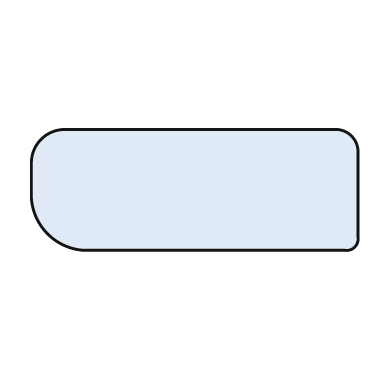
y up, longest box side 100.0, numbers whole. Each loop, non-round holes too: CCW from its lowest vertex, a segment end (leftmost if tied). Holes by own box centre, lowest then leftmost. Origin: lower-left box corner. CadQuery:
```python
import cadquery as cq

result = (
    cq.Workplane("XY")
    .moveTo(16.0, 0.0)
    .lineTo(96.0, 0.0)
    .threePointArc((99.0, 1.0), (100.0, 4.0))
    .lineTo(100.0, 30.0)
    .threePointArc((98.0, 35.0), (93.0, 37.0))
    .lineTo(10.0, 37.0)
    .threePointArc((3.0, 34.0), (0.0, 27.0))
    .lineTo(0.0, 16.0)
    .threePointArc((5.0, 5.0), (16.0, 0.0))
    .close()
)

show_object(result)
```